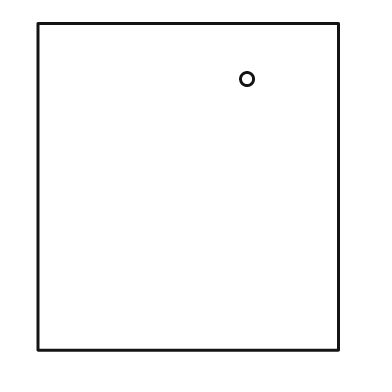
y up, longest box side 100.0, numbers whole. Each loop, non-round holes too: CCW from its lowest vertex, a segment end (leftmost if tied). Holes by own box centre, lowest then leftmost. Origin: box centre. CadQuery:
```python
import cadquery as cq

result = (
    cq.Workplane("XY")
    .moveTo(-46.0, -50.0)
    .lineTo(46.0, -50.0)
    .lineTo(46.0, 50.0)
    .lineTo(-46.0, 50.0)
    .close()
    .moveTo(18.0, 33.0)
    .circle(2.0)
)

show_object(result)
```